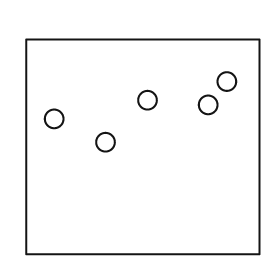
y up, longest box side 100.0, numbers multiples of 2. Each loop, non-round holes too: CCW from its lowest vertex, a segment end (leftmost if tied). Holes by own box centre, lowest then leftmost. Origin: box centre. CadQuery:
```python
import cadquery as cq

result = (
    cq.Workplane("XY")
    .moveTo(-50.0, -46.0)
    .lineTo(50.0, -46.0)
    .lineTo(50.0, 46.0)
    .lineTo(-50.0, 46.0)
    .close()
    .moveTo(-16.0, 2.0)
    .circle(4.0)
    .moveTo(-38.0, 12.0)
    .circle(4.0)
    .moveTo(28.0, 18.0)
    .circle(4.0)
    .moveTo(2.0, 20.0)
    .circle(4.0)
    .moveTo(36.0, 28.0)
    .circle(4.0)
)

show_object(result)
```